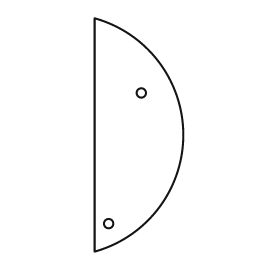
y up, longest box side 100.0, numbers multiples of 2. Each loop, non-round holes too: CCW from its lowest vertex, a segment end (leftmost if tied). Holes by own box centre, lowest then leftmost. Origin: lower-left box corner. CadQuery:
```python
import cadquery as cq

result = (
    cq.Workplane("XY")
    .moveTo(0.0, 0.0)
    .threePointArc((38.0, 50.0), (0.0, 100.0))
    .close()
    .moveTo(6.0, 12.0)
    .circle(2.0)
    .moveTo(20.0, 68.0)
    .circle(2.0)
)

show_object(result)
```